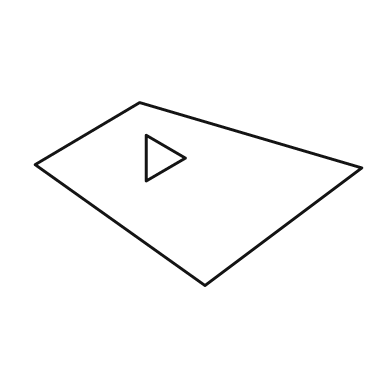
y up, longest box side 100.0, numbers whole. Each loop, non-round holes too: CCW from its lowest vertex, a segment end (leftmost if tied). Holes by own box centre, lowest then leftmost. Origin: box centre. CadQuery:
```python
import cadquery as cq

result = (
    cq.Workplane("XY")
    .moveTo(2.0, -28.0)
    .lineTo(50.0, 8.0)
    .lineTo(-18.0, 28.0)
    .lineTo(-50.0, 9.0)
    .close()
    .moveTo(-16.0, 4.0)
    .lineTo(-4.0, 11.0)
    .lineTo(-16.0, 18.0)
    .close()
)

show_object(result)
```